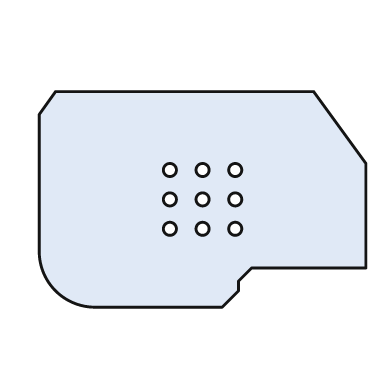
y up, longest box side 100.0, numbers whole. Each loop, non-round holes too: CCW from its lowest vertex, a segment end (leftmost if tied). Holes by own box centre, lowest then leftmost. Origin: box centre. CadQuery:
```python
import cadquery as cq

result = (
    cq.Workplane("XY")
    .moveTo(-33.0, -33.0)
    .lineTo(6.0, -33.0)
    .lineTo(11.0, -28.0)
    .lineTo(11.0, -25.0)
    .lineTo(15.0, -21.0)
    .lineTo(50.0, -21.0)
    .lineTo(50.0, 11.0)
    .lineTo(34.0, 33.0)
    .lineTo(-45.0, 33.0)
    .lineTo(-50.0, 26.0)
    .lineTo(-50.0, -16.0)
    .threePointArc((-45.0, -28.0), (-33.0, -33.0))
    .close()
    .moveTo(-10.0, -9.0)
    .circle(2.0)
    .moveTo(0.0, -9.0)
    .circle(2.0)
    .moveTo(10.0, -9.0)
    .circle(2.0)
    .moveTo(-10.0, 0.0)
    .circle(2.0)
    .moveTo(0.0, 0.0)
    .circle(2.0)
    .moveTo(10.0, 0.0)
    .circle(2.0)
    .moveTo(-10.0, 9.0)
    .circle(2.0)
    .moveTo(0.0, 9.0)
    .circle(2.0)
    .moveTo(10.0, 9.0)
    .circle(2.0)
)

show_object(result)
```